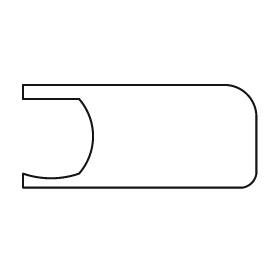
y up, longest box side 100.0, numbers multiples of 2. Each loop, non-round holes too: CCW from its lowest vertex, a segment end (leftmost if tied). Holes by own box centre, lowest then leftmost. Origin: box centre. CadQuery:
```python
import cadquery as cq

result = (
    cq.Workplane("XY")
    .moveTo(-50.0, -22.0)
    .lineTo(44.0, -22.0)
    .threePointArc((48.0, -20.0), (50.0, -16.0))
    .lineTo(50.0, 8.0)
    .threePointArc((46.0, 18.0), (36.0, 22.0))
    .lineTo(-50.0, 22.0)
    .lineTo(-50.0, 16.0)
    .lineTo(-26.0, 16.0)
    .threePointArc((-20.0, 0.0), (-26.0, -16.0))
    .threePointArc((-38.0, -18.0), (-50.0, -16.0))
    .close()
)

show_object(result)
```